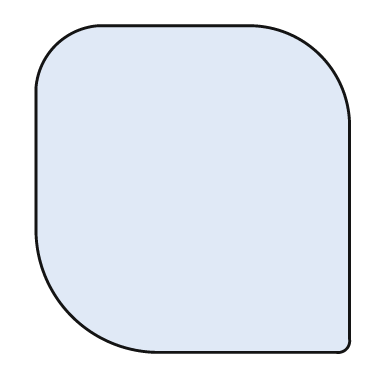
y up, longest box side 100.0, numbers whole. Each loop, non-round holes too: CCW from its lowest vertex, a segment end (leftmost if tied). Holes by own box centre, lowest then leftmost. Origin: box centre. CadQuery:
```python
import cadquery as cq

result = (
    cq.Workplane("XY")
    .moveTo(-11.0, -50.0)
    .lineTo(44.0, -50.0)
    .threePointArc((47.0, -49.0), (48.0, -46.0))
    .lineTo(48.0, 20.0)
    .threePointArc((39.0, 41.0), (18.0, 50.0))
    .lineTo(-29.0, 50.0)
    .threePointArc((-42.0, 44.0), (-48.0, 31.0))
    .lineTo(-48.0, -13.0)
    .threePointArc((-37.0, -39.0), (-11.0, -50.0))
    .close()
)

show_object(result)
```